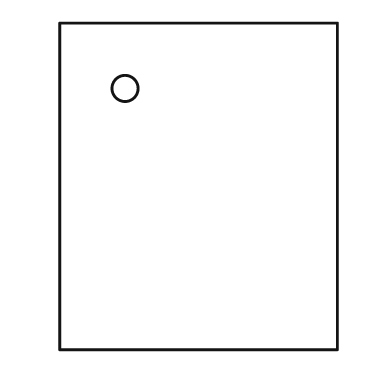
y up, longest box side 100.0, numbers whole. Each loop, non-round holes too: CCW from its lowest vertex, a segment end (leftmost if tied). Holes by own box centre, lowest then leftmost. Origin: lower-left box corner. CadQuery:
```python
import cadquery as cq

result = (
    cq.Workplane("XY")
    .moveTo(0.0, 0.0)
    .lineTo(85.0, 0.0)
    .lineTo(85.0, 100.0)
    .lineTo(0.0, 100.0)
    .close()
    .moveTo(20.0, 80.0)
    .circle(4.0)
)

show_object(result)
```